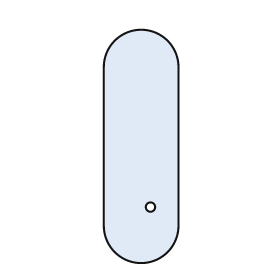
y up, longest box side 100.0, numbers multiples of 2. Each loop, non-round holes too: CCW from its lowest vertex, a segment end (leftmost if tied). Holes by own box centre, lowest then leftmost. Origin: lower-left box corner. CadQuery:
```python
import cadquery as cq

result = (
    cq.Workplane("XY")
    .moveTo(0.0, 16.0)
    .threePointArc((16.0, 0.0), (32.0, 16.0))
    .lineTo(32.0, 84.0)
    .threePointArc((16.0, 100.0), (0.0, 84.0))
    .close()
    .moveTo(20.0, 24.0)
    .circle(2.0)
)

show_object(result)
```